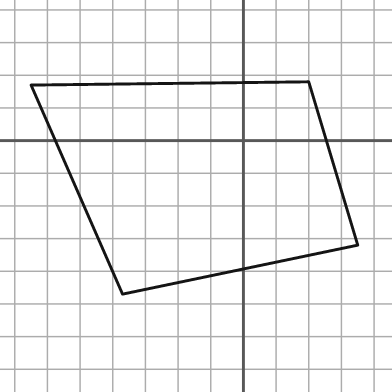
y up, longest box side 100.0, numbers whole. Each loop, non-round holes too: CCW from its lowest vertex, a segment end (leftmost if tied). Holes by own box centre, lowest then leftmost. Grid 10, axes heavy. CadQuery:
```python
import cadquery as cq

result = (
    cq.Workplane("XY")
    .moveTo(-37.0, -47.0)
    .lineTo(35.0, -32.0)
    .lineTo(20.0, 18.0)
    .lineTo(-65.0, 17.0)
    .close()
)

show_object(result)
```